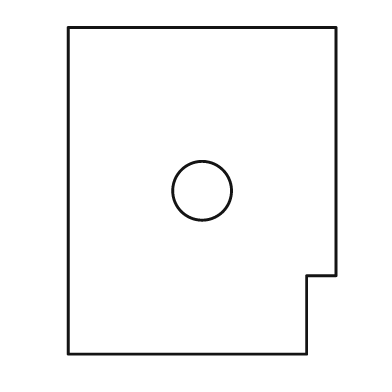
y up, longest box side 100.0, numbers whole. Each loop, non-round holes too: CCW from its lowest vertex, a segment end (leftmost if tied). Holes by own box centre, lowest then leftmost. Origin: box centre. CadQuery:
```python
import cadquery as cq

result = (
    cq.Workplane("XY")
    .moveTo(-41.0, -50.0)
    .lineTo(32.0, -50.0)
    .lineTo(32.0, -26.0)
    .lineTo(41.0, -26.0)
    .lineTo(41.0, 50.0)
    .lineTo(-41.0, 50.0)
    .close()
    .moveTo(0.0, 0.0)
    .circle(9.0)
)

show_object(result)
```